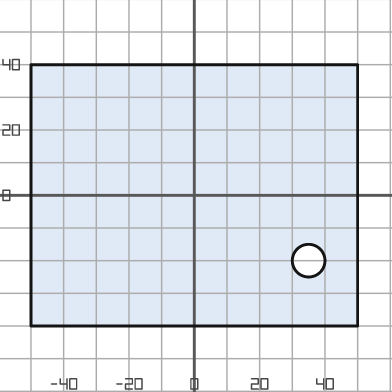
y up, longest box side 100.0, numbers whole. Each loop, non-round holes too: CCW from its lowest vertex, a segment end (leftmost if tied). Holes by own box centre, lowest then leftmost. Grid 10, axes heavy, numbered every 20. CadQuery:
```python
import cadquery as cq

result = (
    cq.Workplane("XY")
    .moveTo(-50.0, -40.0)
    .lineTo(50.0, -40.0)
    .lineTo(50.0, 40.0)
    .lineTo(-50.0, 40.0)
    .close()
    .moveTo(35.0, -20.0)
    .circle(5.0)
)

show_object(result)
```